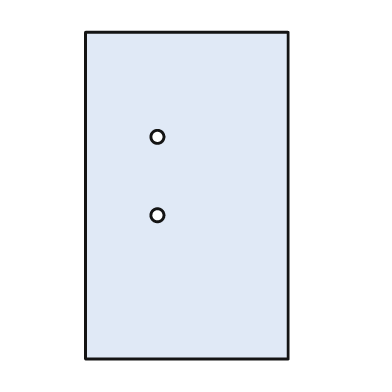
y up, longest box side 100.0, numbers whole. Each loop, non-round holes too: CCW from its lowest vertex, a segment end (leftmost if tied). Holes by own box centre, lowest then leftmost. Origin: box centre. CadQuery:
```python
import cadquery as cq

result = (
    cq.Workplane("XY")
    .moveTo(-31.0, -50.0)
    .lineTo(31.0, -50.0)
    .lineTo(31.0, 50.0)
    .lineTo(-31.0, 50.0)
    .close()
    .moveTo(-9.0, -6.0)
    .circle(2.0)
    .moveTo(-9.0, 18.0)
    .circle(2.0)
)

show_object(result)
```